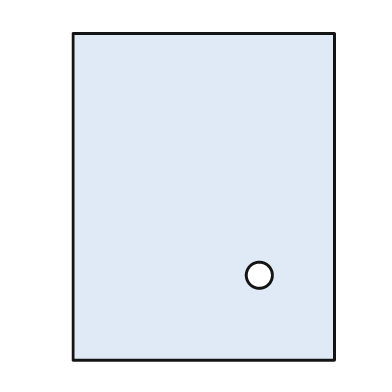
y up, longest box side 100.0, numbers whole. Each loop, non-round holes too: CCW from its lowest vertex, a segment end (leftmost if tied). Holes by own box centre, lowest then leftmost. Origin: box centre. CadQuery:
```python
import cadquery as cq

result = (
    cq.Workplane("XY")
    .moveTo(-40.0, -50.0)
    .lineTo(40.0, -50.0)
    .lineTo(40.0, 50.0)
    .lineTo(-40.0, 50.0)
    .close()
    .moveTo(17.0, -24.0)
    .circle(4.0)
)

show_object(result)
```